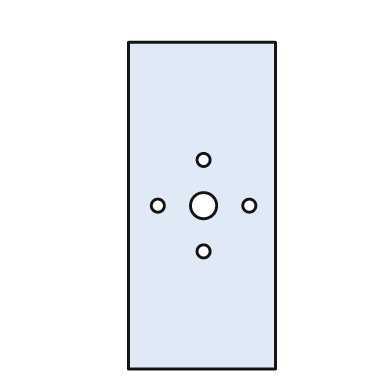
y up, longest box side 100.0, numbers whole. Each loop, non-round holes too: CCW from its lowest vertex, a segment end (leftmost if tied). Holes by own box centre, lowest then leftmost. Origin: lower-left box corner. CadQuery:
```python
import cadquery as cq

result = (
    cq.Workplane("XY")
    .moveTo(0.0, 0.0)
    .lineTo(45.0, 0.0)
    .lineTo(45.0, 100.0)
    .lineTo(0.0, 100.0)
    .close()
    .moveTo(23.0, 36.0)
    .circle(2.0)
    .moveTo(9.0, 50.0)
    .circle(2.0)
    .moveTo(23.0, 50.0)
    .circle(4.0)
    .moveTo(37.0, 50.0)
    .circle(2.0)
    .moveTo(23.0, 64.0)
    .circle(2.0)
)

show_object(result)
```